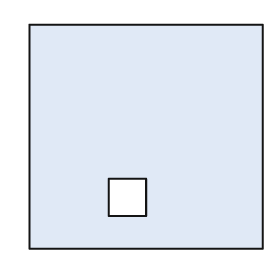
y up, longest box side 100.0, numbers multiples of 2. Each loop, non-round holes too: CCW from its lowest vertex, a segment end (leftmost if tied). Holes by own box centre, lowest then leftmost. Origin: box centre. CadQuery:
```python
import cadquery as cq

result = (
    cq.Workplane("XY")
    .moveTo(-50.0, -48.0)
    .lineTo(50.0, -48.0)
    .lineTo(50.0, 48.0)
    .lineTo(-50.0, 48.0)
    .close()
    .moveTo(-16.0, -34.0)
    .lineTo(0.0, -34.0)
    .lineTo(0.0, -18.0)
    .lineTo(-16.0, -18.0)
    .close()
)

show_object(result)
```